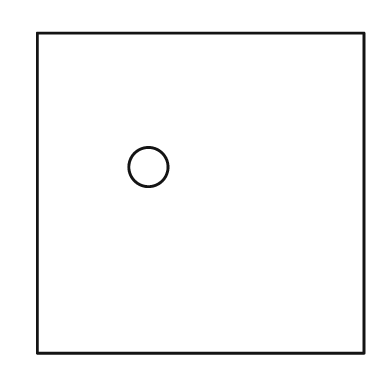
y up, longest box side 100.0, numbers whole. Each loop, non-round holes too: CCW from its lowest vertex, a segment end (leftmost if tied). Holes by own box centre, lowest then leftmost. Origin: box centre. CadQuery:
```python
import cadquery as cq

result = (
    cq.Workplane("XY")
    .moveTo(-50.0, -49.0)
    .lineTo(50.0, -49.0)
    .lineTo(50.0, 49.0)
    .lineTo(-50.0, 49.0)
    .close()
    .moveTo(-16.0, 8.0)
    .circle(6.0)
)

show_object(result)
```